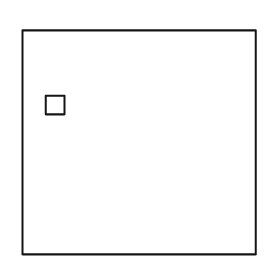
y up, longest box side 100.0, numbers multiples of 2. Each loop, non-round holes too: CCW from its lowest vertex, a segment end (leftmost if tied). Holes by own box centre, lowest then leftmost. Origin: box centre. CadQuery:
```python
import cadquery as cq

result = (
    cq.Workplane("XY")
    .moveTo(-50.0, -48.0)
    .lineTo(50.0, -48.0)
    .lineTo(50.0, 48.0)
    .lineTo(-50.0, 48.0)
    .close()
    .moveTo(-40.0, 12.0)
    .lineTo(-32.0, 12.0)
    .lineTo(-32.0, 20.0)
    .lineTo(-40.0, 20.0)
    .close()
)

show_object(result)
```